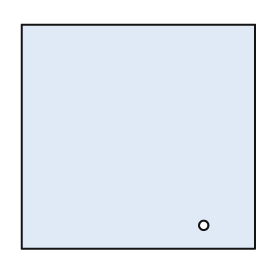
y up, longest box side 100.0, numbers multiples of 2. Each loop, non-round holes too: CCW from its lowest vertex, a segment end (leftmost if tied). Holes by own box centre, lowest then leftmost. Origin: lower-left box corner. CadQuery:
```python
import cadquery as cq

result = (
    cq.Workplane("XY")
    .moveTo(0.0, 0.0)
    .lineTo(100.0, 0.0)
    .lineTo(100.0, 96.0)
    .lineTo(0.0, 96.0)
    .close()
    .moveTo(78.0, 10.0)
    .circle(2.0)
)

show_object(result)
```